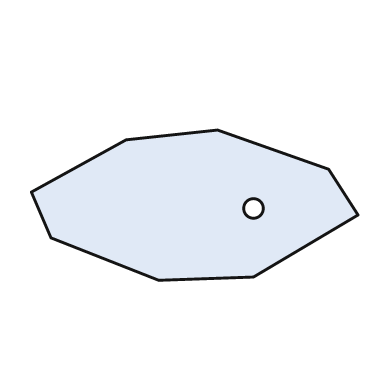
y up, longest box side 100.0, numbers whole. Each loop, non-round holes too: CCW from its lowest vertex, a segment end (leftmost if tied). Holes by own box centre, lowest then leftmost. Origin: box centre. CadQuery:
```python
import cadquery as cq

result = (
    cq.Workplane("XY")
    .moveTo(-11.0, -23.0)
    .lineTo(18.0, -22.0)
    .lineTo(50.0, -3.0)
    .lineTo(41.0, 11.0)
    .lineTo(7.0, 23.0)
    .lineTo(-21.0, 20.0)
    .lineTo(-50.0, 4.0)
    .lineTo(-44.0, -10.0)
    .close()
    .moveTo(18.0, -1.0)
    .circle(3.0)
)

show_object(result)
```